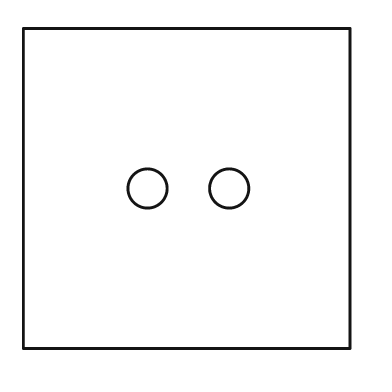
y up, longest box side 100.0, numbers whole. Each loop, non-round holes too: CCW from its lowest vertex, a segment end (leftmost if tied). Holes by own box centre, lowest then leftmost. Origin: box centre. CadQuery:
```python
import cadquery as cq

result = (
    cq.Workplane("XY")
    .moveTo(-50.0, -49.0)
    .lineTo(50.0, -49.0)
    .lineTo(50.0, 49.0)
    .lineTo(-50.0, 49.0)
    .close()
    .moveTo(-12.0, 0.0)
    .circle(6.0)
    .moveTo(13.0, 0.0)
    .circle(6.0)
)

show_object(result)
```